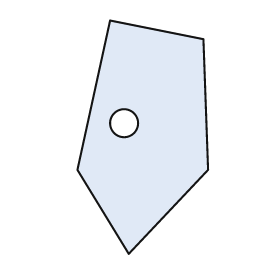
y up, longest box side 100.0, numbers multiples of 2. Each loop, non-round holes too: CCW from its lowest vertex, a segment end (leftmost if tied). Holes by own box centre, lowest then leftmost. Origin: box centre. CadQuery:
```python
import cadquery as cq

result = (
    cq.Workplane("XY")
    .moveTo(-6.0, -50.0)
    .lineTo(28.0, -14.0)
    .lineTo(26.0, 42.0)
    .lineTo(-14.0, 50.0)
    .lineTo(-28.0, -14.0)
    .close()
    .moveTo(-8.0, 6.0)
    .circle(6.0)
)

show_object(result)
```